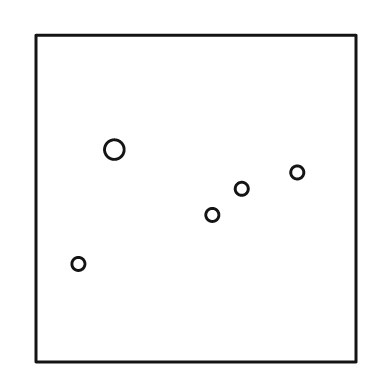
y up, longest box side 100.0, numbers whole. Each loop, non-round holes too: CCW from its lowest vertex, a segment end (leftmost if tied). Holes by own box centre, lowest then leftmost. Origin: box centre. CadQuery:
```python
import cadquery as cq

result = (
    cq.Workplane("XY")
    .moveTo(-49.0, -50.0)
    .lineTo(49.0, -50.0)
    .lineTo(49.0, 50.0)
    .lineTo(-49.0, 50.0)
    .close()
    .moveTo(-36.0, -20.0)
    .circle(2.0)
    .moveTo(5.0, -5.0)
    .circle(2.0)
    .moveTo(14.0, 3.0)
    .circle(2.0)
    .moveTo(31.0, 8.0)
    .circle(2.0)
    .moveTo(-25.0, 15.0)
    .circle(3.0)
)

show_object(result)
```